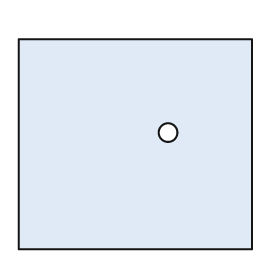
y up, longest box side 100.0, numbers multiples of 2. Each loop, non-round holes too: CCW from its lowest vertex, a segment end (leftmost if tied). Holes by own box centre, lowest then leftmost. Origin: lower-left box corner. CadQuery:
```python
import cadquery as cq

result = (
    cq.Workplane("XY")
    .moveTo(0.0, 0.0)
    .lineTo(100.0, 0.0)
    .lineTo(100.0, 90.0)
    .lineTo(0.0, 90.0)
    .close()
    .moveTo(64.0, 50.0)
    .circle(4.0)
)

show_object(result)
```